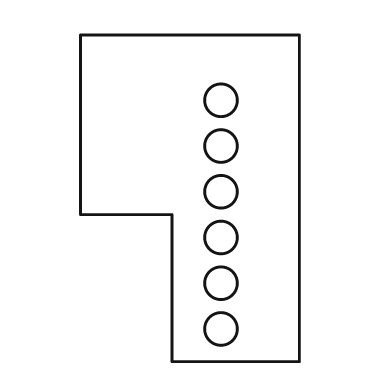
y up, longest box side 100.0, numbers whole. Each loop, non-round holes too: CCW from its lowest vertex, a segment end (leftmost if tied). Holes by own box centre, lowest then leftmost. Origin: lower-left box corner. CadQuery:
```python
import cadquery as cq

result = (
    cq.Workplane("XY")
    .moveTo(28.0, 0.0)
    .lineTo(67.0, 0.0)
    .lineTo(67.0, 100.0)
    .lineTo(0.0, 100.0)
    .lineTo(0.0, 45.0)
    .lineTo(28.0, 45.0)
    .close()
    .moveTo(43.0, 10.0)
    .circle(5.0)
    .moveTo(43.0, 24.0)
    .circle(5.0)
    .moveTo(43.0, 38.0)
    .circle(5.0)
    .moveTo(43.0, 52.0)
    .circle(5.0)
    .moveTo(43.0, 66.0)
    .circle(5.0)
    .moveTo(43.0, 80.0)
    .circle(5.0)
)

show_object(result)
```